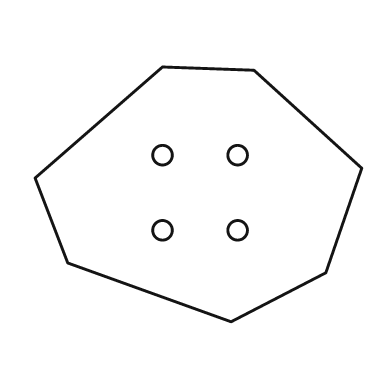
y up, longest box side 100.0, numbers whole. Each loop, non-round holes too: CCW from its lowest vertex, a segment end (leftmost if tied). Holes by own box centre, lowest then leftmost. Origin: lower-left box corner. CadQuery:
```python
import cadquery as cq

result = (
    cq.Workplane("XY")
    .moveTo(60.0, 0.0)
    .lineTo(89.0, 15.0)
    .lineTo(100.0, 47.0)
    .lineTo(67.0, 77.0)
    .lineTo(39.0, 78.0)
    .lineTo(0.0, 44.0)
    .lineTo(10.0, 18.0)
    .close()
    .moveTo(39.0, 28.0)
    .circle(3.0)
    .moveTo(62.0, 28.0)
    .circle(3.0)
    .moveTo(39.0, 51.0)
    .circle(3.0)
    .moveTo(62.0, 51.0)
    .circle(3.0)
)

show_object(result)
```